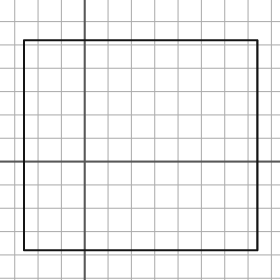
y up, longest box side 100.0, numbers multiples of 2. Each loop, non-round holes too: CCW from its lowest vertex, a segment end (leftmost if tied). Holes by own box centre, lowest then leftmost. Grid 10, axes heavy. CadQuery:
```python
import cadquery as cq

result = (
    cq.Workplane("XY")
    .moveTo(-26.0, -38.0)
    .lineTo(74.0, -38.0)
    .lineTo(74.0, 52.0)
    .lineTo(-26.0, 52.0)
    .close()
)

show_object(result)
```